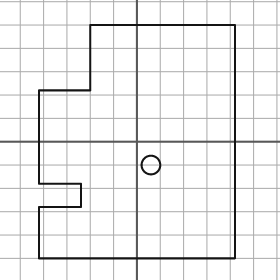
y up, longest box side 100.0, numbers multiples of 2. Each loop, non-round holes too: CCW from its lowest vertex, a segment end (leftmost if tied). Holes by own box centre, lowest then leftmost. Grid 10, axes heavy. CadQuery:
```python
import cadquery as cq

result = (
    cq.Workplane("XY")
    .moveTo(-42.0, -50.0)
    .lineTo(42.0, -50.0)
    .lineTo(42.0, 50.0)
    .lineTo(-20.0, 50.0)
    .lineTo(-20.0, 22.0)
    .lineTo(-42.0, 22.0)
    .lineTo(-42.0, -18.0)
    .lineTo(-24.0, -18.0)
    .lineTo(-24.0, -28.0)
    .lineTo(-42.0, -28.0)
    .close()
    .moveTo(6.0, -10.0)
    .circle(4.0)
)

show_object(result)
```